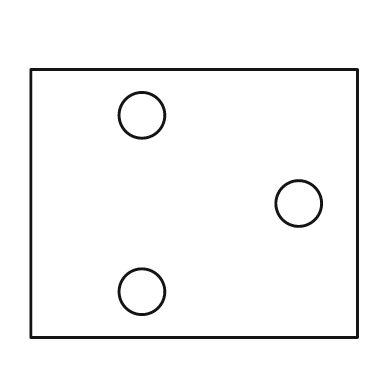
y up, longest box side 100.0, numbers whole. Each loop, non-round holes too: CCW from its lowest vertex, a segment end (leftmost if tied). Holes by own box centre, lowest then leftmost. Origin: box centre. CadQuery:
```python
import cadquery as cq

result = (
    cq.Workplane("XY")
    .moveTo(-50.0, -41.0)
    .lineTo(50.0, -41.0)
    .lineTo(50.0, 41.0)
    .lineTo(-50.0, 41.0)
    .close()
    .moveTo(-16.0, -27.0)
    .circle(7.0)
    .moveTo(32.0, 0.0)
    .circle(7.0)
    .moveTo(-16.0, 27.0)
    .circle(7.0)
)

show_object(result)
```